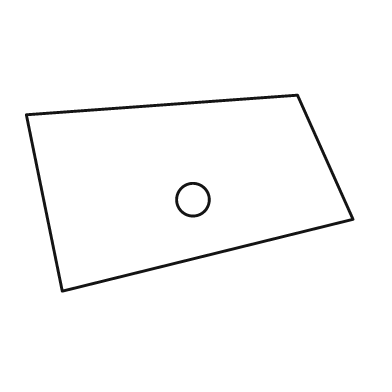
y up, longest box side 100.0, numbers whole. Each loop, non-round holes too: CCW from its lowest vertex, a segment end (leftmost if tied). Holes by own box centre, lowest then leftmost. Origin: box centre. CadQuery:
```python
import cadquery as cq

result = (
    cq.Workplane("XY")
    .moveTo(-39.0, -30.0)
    .lineTo(50.0, -8.0)
    .lineTo(33.0, 30.0)
    .lineTo(-50.0, 24.0)
    .close()
    .moveTo(1.0, -2.0)
    .circle(5.0)
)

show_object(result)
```